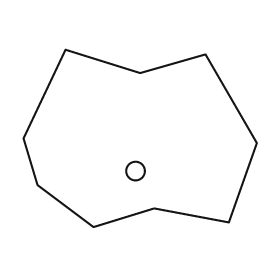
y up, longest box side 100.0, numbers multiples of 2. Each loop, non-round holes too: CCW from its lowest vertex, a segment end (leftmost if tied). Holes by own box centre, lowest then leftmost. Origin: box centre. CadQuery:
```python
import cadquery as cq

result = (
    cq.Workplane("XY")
    .moveTo(-20.0, -38.0)
    .lineTo(6.0, -30.0)
    .lineTo(38.0, -36.0)
    .lineTo(50.0, -2.0)
    .lineTo(28.0, 36.0)
    .lineTo(0.0, 28.0)
    .lineTo(-32.0, 38.0)
    .lineTo(-50.0, 0.0)
    .lineTo(-44.0, -20.0)
    .close()
    .moveTo(-2.0, -14.0)
    .circle(4.0)
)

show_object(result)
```